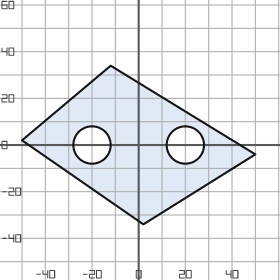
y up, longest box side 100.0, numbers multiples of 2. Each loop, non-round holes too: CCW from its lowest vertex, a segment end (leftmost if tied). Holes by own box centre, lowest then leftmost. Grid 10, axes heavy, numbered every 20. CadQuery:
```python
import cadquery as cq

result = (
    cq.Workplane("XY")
    .moveTo(2.0, -34.0)
    .lineTo(50.0, -4.0)
    .lineTo(-12.0, 34.0)
    .lineTo(-50.0, 2.0)
    .close()
    .moveTo(-20.0, 0.0)
    .circle(8.0)
    .moveTo(20.0, 0.0)
    .circle(8.0)
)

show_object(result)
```